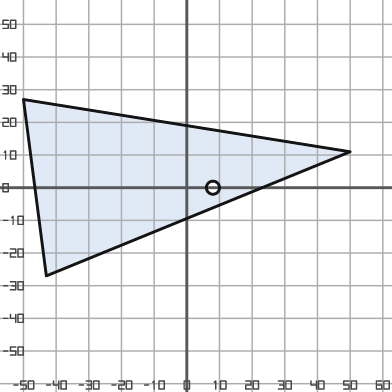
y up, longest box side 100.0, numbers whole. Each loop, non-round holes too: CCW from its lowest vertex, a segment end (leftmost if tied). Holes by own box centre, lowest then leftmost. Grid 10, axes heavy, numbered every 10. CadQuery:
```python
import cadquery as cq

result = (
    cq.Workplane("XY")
    .moveTo(-43.0, -27.0)
    .lineTo(50.0, 11.0)
    .lineTo(-50.0, 27.0)
    .close()
    .moveTo(8.0, 0.0)
    .circle(2.0)
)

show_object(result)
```